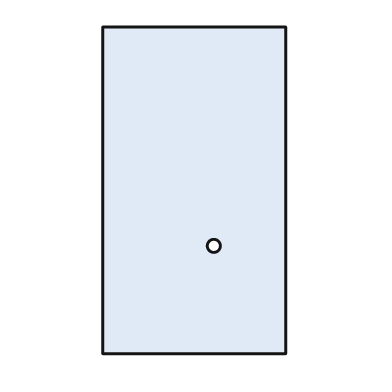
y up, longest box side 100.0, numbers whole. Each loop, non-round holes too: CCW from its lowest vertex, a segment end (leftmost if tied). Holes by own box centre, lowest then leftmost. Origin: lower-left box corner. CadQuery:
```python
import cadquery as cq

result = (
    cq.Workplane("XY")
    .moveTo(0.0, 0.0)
    .lineTo(56.0, 0.0)
    .lineTo(56.0, 100.0)
    .lineTo(0.0, 100.0)
    .close()
    .moveTo(34.0, 33.0)
    .circle(2.0)
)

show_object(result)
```